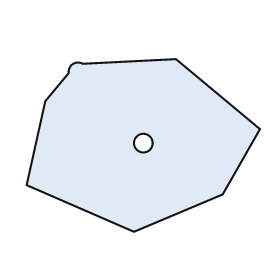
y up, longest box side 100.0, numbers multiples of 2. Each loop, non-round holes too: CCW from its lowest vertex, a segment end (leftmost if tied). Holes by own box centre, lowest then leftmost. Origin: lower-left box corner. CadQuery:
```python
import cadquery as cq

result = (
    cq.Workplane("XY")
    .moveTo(46.0, 0.0)
    .lineTo(84.0, 16.0)
    .lineTo(100.0, 44.0)
    .lineTo(64.0, 74.0)
    .lineTo(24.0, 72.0)
    .threePointArc((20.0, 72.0), (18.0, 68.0))
    .lineTo(8.0, 56.0)
    .lineTo(0.0, 20.0)
    .close()
    .moveTo(50.0, 38.0)
    .circle(4.0)
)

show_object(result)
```